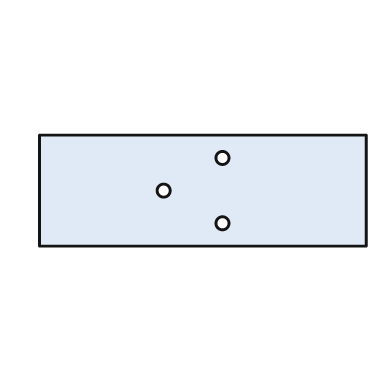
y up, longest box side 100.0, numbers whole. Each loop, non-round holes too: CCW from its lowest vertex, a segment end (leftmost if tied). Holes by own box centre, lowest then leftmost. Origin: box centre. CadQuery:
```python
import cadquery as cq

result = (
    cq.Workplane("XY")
    .moveTo(-50.0, -17.0)
    .lineTo(50.0, -17.0)
    .lineTo(50.0, 17.0)
    .lineTo(-50.0, 17.0)
    .close()
    .moveTo(6.0, -10.0)
    .circle(2.0)
    .moveTo(-12.0, 0.0)
    .circle(2.0)
    .moveTo(6.0, 10.0)
    .circle(2.0)
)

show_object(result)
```